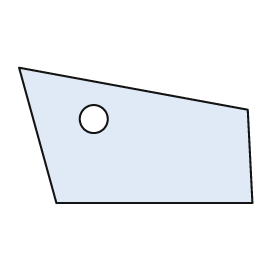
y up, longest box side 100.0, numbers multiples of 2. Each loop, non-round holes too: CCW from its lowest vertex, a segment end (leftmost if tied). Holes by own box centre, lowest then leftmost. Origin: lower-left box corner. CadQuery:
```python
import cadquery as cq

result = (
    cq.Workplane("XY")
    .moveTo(16.0, 0.0)
    .lineTo(100.0, 0.0)
    .lineTo(98.0, 40.0)
    .lineTo(0.0, 58.0)
    .close()
    .moveTo(32.0, 36.0)
    .circle(6.0)
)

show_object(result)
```